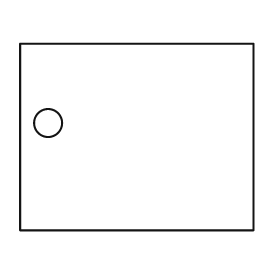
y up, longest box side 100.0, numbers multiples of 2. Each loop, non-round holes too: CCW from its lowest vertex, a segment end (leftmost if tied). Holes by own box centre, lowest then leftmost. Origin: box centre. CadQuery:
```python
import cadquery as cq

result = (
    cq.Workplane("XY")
    .moveTo(-50.0, -40.0)
    .lineTo(50.0, -40.0)
    .lineTo(50.0, 40.0)
    .lineTo(-50.0, 40.0)
    .close()
    .moveTo(-38.0, 6.0)
    .circle(6.0)
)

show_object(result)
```